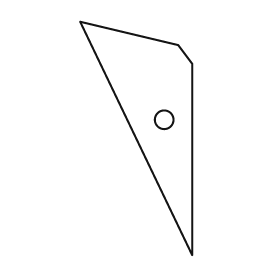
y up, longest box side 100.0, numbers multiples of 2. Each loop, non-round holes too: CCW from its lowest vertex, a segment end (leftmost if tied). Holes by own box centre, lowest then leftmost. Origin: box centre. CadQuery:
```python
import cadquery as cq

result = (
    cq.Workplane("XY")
    .moveTo(24.0, -50.0)
    .lineTo(24.0, 32.0)
    .lineTo(18.0, 40.0)
    .lineTo(-24.0, 50.0)
    .close()
    .moveTo(12.0, 8.0)
    .circle(4.0)
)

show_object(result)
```